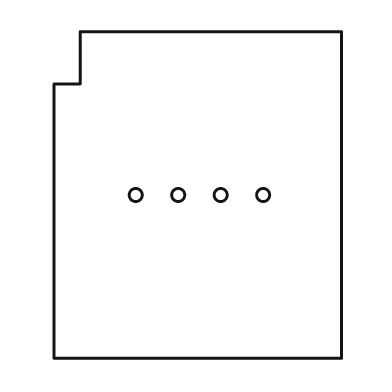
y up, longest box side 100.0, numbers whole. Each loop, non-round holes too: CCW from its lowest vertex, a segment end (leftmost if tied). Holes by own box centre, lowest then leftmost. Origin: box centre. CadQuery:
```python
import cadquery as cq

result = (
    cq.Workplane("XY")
    .moveTo(-44.0, -50.0)
    .lineTo(44.0, -50.0)
    .lineTo(44.0, 50.0)
    .lineTo(-36.0, 50.0)
    .lineTo(-36.0, 34.0)
    .lineTo(-44.0, 34.0)
    .close()
    .moveTo(-19.0, 0.0)
    .circle(2.0)
    .moveTo(-6.0, 0.0)
    .circle(2.0)
    .moveTo(7.0, 0.0)
    .circle(2.0)
    .moveTo(20.0, 0.0)
    .circle(2.0)
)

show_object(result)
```